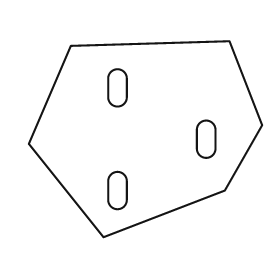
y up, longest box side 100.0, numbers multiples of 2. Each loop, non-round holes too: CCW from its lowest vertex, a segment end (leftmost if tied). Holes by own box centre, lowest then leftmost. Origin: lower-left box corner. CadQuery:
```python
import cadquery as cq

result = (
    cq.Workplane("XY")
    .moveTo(32.0, 0.0)
    .lineTo(84.0, 20.0)
    .lineTo(100.0, 48.0)
    .lineTo(86.0, 84.0)
    .lineTo(18.0, 82.0)
    .lineTo(0.0, 40.0)
    .close()
    .moveTo(34.0, 16.0)
    .threePointArc((38.0, 12.0), (42.0, 16.0))
    .lineTo(42.0, 24.0)
    .threePointArc((38.0, 28.0), (34.0, 24.0))
    .close()
    .moveTo(72.0, 38.0)
    .threePointArc((76.0, 34.0), (80.0, 38.0))
    .lineTo(80.0, 46.0)
    .threePointArc((76.0, 50.0), (72.0, 46.0))
    .close()
    .moveTo(34.0, 60.0)
    .threePointArc((38.0, 56.0), (42.0, 60.0))
    .lineTo(42.0, 68.0)
    .threePointArc((38.0, 72.0), (34.0, 68.0))
    .close()
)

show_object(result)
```